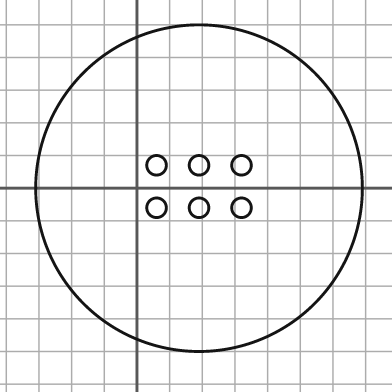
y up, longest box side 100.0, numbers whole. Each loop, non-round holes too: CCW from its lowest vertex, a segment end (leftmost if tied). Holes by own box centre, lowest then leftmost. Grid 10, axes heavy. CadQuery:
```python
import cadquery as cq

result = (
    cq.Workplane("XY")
    .moveTo(19.0, 0.0)
    .circle(50.0)
    .moveTo(6.0, -6.0)
    .circle(3.0)
    .moveTo(19.0, -6.0)
    .circle(3.0)
    .moveTo(32.0, -6.0)
    .circle(3.0)
    .moveTo(6.0, 7.0)
    .circle(3.0)
    .moveTo(19.0, 7.0)
    .circle(3.0)
    .moveTo(32.0, 7.0)
    .circle(3.0)
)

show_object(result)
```